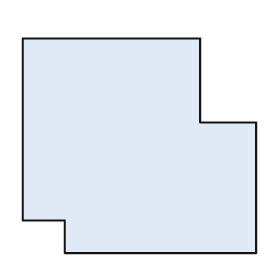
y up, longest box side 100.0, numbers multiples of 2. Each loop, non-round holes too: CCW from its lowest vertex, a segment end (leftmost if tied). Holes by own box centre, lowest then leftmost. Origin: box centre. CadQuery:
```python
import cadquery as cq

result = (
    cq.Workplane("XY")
    .moveTo(-32.0, -46.0)
    .lineTo(50.0, -46.0)
    .lineTo(50.0, 10.0)
    .lineTo(26.0, 10.0)
    .lineTo(26.0, 46.0)
    .lineTo(-50.0, 46.0)
    .lineTo(-50.0, -32.0)
    .lineTo(-32.0, -32.0)
    .close()
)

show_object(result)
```